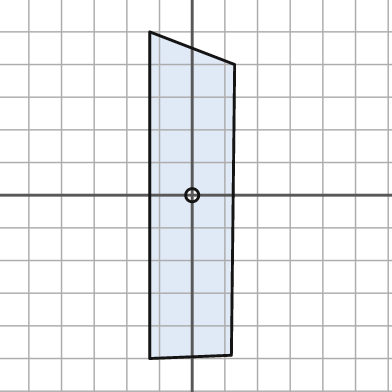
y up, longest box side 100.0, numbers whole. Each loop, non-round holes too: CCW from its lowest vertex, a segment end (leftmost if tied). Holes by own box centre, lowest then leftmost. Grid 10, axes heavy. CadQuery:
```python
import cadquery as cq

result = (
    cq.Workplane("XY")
    .moveTo(-13.0, -50.0)
    .lineTo(12.0, -49.0)
    .lineTo(13.0, 40.0)
    .lineTo(-13.0, 50.0)
    .close()
    .moveTo(0.0, 0.0)
    .circle(2.0)
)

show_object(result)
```